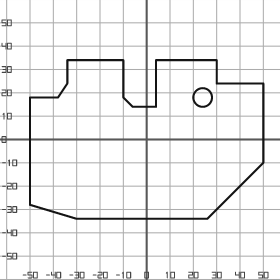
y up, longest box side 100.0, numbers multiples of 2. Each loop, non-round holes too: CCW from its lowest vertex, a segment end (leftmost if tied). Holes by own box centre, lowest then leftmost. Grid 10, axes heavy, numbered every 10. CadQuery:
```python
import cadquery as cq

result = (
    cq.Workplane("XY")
    .moveTo(-30.0, -34.0)
    .lineTo(26.0, -34.0)
    .lineTo(50.0, -10.0)
    .lineTo(50.0, 24.0)
    .lineTo(30.0, 24.0)
    .lineTo(30.0, 34.0)
    .lineTo(4.0, 34.0)
    .lineTo(4.0, 14.0)
    .lineTo(-6.0, 14.0)
    .lineTo(-10.0, 18.0)
    .lineTo(-10.0, 34.0)
    .lineTo(-34.0, 34.0)
    .lineTo(-34.0, 24.0)
    .lineTo(-38.0, 18.0)
    .lineTo(-50.0, 18.0)
    .lineTo(-50.0, -28.0)
    .close()
    .moveTo(24.0, 18.0)
    .circle(4.0)
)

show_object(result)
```